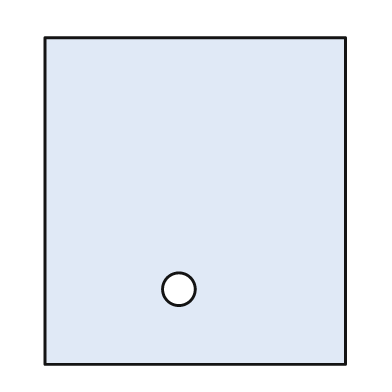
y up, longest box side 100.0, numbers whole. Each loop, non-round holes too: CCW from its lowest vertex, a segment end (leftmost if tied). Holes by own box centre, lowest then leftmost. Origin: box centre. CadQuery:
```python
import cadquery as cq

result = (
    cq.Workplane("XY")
    .moveTo(-46.0, -50.0)
    .lineTo(46.0, -50.0)
    .lineTo(46.0, 50.0)
    .lineTo(-46.0, 50.0)
    .close()
    .moveTo(-5.0, -27.0)
    .circle(5.0)
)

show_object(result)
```